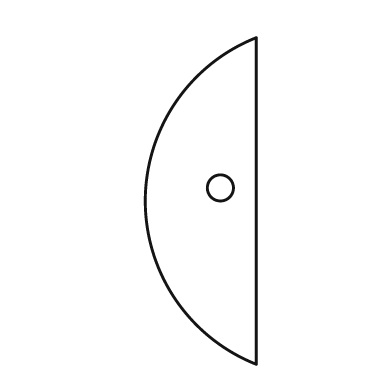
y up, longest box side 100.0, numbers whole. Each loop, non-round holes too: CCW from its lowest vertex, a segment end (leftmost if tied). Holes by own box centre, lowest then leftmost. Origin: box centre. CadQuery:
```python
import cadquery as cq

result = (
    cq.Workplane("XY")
    .moveTo(17.0, -50.0)
    .lineTo(17.0, 50.0)
    .threePointArc((-17.0, 0.0), (17.0, -50.0))
    .close()
    .moveTo(6.0, 4.0)
    .circle(4.0)
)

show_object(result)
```